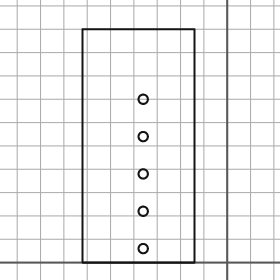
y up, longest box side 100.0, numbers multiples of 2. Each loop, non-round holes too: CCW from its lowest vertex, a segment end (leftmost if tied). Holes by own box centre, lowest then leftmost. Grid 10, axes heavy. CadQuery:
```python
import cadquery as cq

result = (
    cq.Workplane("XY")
    .moveTo(-62.0, 0.0)
    .lineTo(-14.0, 0.0)
    .lineTo(-14.0, 100.0)
    .lineTo(-62.0, 100.0)
    .close()
    .moveTo(-36.0, 6.0)
    .circle(2.0)
    .moveTo(-36.0, 22.0)
    .circle(2.0)
    .moveTo(-36.0, 38.0)
    .circle(2.0)
    .moveTo(-36.0, 54.0)
    .circle(2.0)
    .moveTo(-36.0, 70.0)
    .circle(2.0)
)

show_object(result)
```